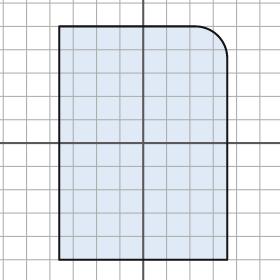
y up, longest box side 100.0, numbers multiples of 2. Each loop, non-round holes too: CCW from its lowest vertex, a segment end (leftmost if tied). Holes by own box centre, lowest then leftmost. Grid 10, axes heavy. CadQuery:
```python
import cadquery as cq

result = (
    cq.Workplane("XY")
    .moveTo(-36.0, -50.0)
    .lineTo(36.0, -50.0)
    .lineTo(36.0, 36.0)
    .threePointArc((32.0, 46.0), (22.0, 50.0))
    .lineTo(-36.0, 50.0)
    .close()
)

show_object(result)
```